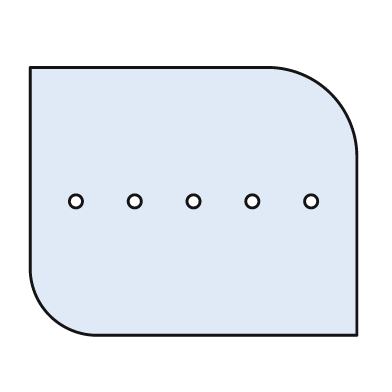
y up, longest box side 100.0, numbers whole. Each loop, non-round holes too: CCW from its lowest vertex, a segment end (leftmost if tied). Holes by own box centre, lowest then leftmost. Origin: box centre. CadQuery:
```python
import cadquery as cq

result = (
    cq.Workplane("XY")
    .moveTo(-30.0, -41.0)
    .lineTo(50.0, -41.0)
    .lineTo(50.0, 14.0)
    .threePointArc((42.0, 33.0), (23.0, 41.0))
    .lineTo(-50.0, 41.0)
    .lineTo(-50.0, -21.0)
    .threePointArc((-44.0, -35.0), (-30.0, -41.0))
    .close()
    .moveTo(-36.0, 0.0)
    .circle(2.0)
    .moveTo(-18.0, 0.0)
    .circle(2.0)
    .moveTo(0.0, 0.0)
    .circle(2.0)
    .moveTo(18.0, 0.0)
    .circle(2.0)
    .moveTo(36.0, 0.0)
    .circle(2.0)
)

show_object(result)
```